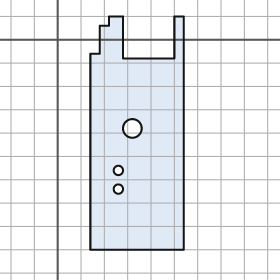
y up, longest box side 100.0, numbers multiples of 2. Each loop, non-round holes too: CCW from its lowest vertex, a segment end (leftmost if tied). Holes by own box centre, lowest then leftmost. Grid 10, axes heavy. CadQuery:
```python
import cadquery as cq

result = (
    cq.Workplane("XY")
    .moveTo(14.0, -90.0)
    .lineTo(54.0, -90.0)
    .lineTo(54.0, 10.0)
    .lineTo(50.0, 10.0)
    .lineTo(50.0, -8.0)
    .lineTo(28.0, -8.0)
    .lineTo(28.0, 10.0)
    .lineTo(22.0, 10.0)
    .lineTo(22.0, 6.0)
    .lineTo(18.0, 6.0)
    .lineTo(18.0, -6.0)
    .lineTo(14.0, -6.0)
    .close()
    .moveTo(26.0, -64.0)
    .circle(2.0)
    .moveTo(26.0, -56.0)
    .circle(2.0)
    .moveTo(32.0, -38.0)
    .circle(4.0)
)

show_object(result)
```